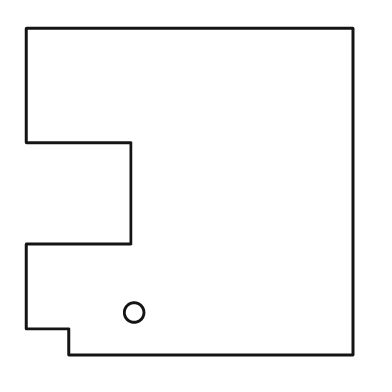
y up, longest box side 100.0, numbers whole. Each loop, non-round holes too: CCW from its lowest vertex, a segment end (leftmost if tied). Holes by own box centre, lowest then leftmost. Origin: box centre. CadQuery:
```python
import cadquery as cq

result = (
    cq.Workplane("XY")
    .moveTo(-37.0, -50.0)
    .lineTo(50.0, -50.0)
    .lineTo(50.0, 50.0)
    .lineTo(-50.0, 50.0)
    .lineTo(-50.0, 15.0)
    .lineTo(-18.0, 15.0)
    .lineTo(-18.0, -16.0)
    .lineTo(-50.0, -16.0)
    .lineTo(-50.0, -42.0)
    .lineTo(-37.0, -42.0)
    .close()
    .moveTo(-17.0, -37.0)
    .circle(3.0)
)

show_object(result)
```